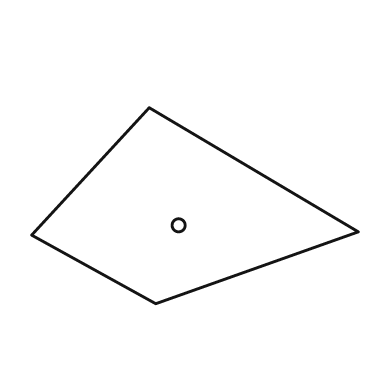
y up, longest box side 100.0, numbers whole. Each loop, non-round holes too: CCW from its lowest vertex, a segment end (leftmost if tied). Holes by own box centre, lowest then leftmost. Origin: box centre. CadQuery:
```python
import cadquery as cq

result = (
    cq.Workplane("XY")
    .moveTo(-12.0, -30.0)
    .lineTo(50.0, -8.0)
    .lineTo(-14.0, 30.0)
    .lineTo(-50.0, -9.0)
    .close()
    .moveTo(-5.0, -6.0)
    .circle(2.0)
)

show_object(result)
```